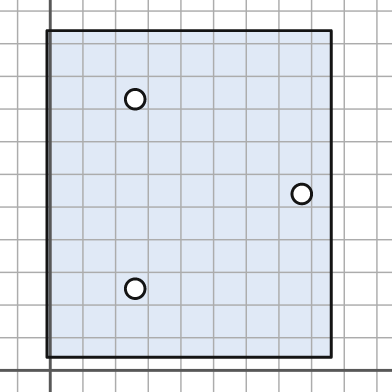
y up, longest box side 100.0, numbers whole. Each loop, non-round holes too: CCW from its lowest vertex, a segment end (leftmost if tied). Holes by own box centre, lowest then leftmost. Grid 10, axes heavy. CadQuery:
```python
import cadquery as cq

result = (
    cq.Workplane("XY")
    .moveTo(-1.0, 4.0)
    .lineTo(86.0, 4.0)
    .lineTo(86.0, 104.0)
    .lineTo(-1.0, 104.0)
    .close()
    .moveTo(26.0, 25.0)
    .circle(3.0)
    .moveTo(77.0, 54.0)
    .circle(3.0)
    .moveTo(26.0, 83.0)
    .circle(3.0)
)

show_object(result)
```